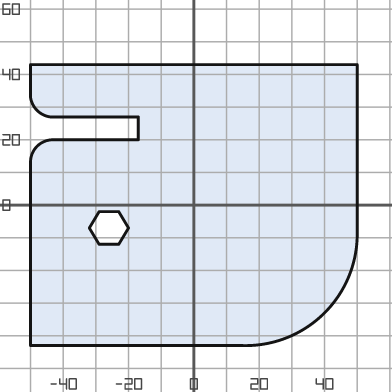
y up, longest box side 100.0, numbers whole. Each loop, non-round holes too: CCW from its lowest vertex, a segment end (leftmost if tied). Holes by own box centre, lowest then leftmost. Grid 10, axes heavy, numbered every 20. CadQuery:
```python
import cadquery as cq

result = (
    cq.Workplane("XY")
    .moveTo(-50.0, -43.0)
    .lineTo(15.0, -43.0)
    .threePointArc((40.0, -33.0), (50.0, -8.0))
    .lineTo(50.0, 43.0)
    .lineTo(-50.0, 43.0)
    .lineTo(-50.0, 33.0)
    .threePointArc((-48.0, 29.0), (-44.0, 27.0))
    .lineTo(-17.0, 27.0)
    .lineTo(-17.0, 20.0)
    .lineTo(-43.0, 20.0)
    .threePointArc((-48.0, 18.0), (-50.0, 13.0))
    .close()
    .moveTo(-29.0, -12.0)
    .lineTo(-23.0, -12.0)
    .lineTo(-20.0, -7.0)
    .lineTo(-23.0, -2.0)
    .lineTo(-29.0, -2.0)
    .lineTo(-32.0, -7.0)
    .close()
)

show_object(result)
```